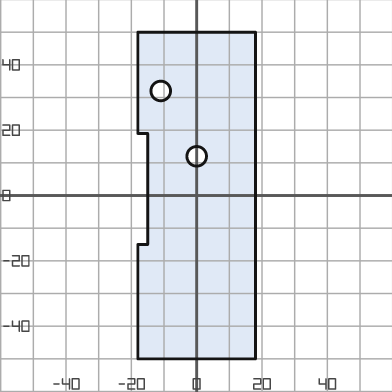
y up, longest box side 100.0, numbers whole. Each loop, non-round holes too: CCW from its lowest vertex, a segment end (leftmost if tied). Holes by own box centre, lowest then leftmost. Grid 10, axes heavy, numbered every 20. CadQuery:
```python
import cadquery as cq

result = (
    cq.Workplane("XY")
    .moveTo(-18.0, -50.0)
    .lineTo(18.0, -50.0)
    .lineTo(18.0, 50.0)
    .lineTo(-18.0, 50.0)
    .lineTo(-18.0, 19.0)
    .lineTo(-15.0, 19.0)
    .lineTo(-15.0, -15.0)
    .lineTo(-18.0, -15.0)
    .close()
    .moveTo(0.0, 12.0)
    .circle(3.0)
    .moveTo(-11.0, 32.0)
    .circle(3.0)
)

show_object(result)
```